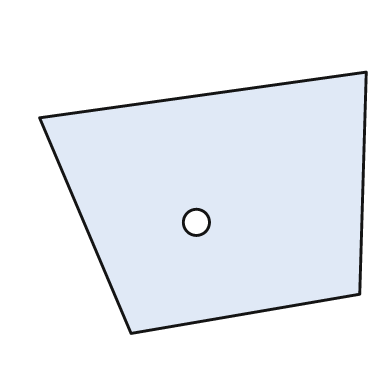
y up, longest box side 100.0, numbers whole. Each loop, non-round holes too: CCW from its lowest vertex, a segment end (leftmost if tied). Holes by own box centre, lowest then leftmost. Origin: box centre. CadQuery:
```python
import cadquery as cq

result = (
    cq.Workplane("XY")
    .moveTo(-22.0, -40.0)
    .lineTo(48.0, -28.0)
    .lineTo(50.0, 40.0)
    .lineTo(-50.0, 26.0)
    .close()
    .moveTo(-2.0, -6.0)
    .circle(4.0)
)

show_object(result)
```